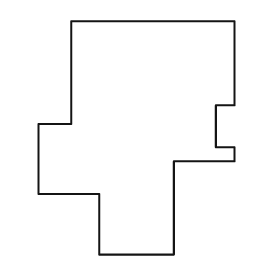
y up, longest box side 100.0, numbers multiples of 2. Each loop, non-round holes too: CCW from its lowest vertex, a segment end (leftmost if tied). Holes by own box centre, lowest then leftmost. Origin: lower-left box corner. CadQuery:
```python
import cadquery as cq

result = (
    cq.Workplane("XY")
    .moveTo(26.0, 0.0)
    .lineTo(58.0, 0.0)
    .lineTo(58.0, 40.0)
    .lineTo(84.0, 40.0)
    .lineTo(84.0, 46.0)
    .lineTo(76.0, 46.0)
    .lineTo(76.0, 64.0)
    .lineTo(84.0, 64.0)
    .lineTo(84.0, 100.0)
    .lineTo(14.0, 100.0)
    .lineTo(14.0, 56.0)
    .lineTo(0.0, 56.0)
    .lineTo(0.0, 26.0)
    .lineTo(26.0, 26.0)
    .close()
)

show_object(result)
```